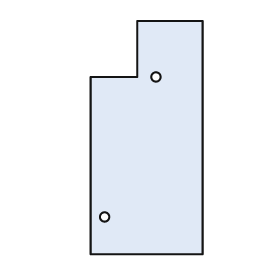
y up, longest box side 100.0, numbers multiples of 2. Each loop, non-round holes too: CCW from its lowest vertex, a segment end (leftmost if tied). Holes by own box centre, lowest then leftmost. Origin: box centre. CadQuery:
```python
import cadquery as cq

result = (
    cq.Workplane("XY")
    .moveTo(-24.0, -50.0)
    .lineTo(24.0, -50.0)
    .lineTo(24.0, 50.0)
    .lineTo(-4.0, 50.0)
    .lineTo(-4.0, 26.0)
    .lineTo(-24.0, 26.0)
    .close()
    .moveTo(-18.0, -34.0)
    .circle(2.0)
    .moveTo(4.0, 26.0)
    .circle(2.0)
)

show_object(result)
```